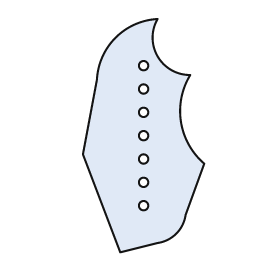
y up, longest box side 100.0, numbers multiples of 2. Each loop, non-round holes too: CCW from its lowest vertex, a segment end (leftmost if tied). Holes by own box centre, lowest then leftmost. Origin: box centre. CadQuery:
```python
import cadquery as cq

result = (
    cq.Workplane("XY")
    .moveTo(-10.0, -50.0)
    .lineTo(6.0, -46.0)
    .threePointArc((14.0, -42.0), (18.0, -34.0))
    .lineTo(26.0, -12.0)
    .threePointArc((16.0, 6.0), (20.0, 26.0))
    .threePointArc((6.0, 34.0), (6.0, 50.0))
    .threePointArc((-12.0, 42.0), (-20.0, 24.0))
    .lineTo(-26.0, -8.0)
    .close()
    .moveTo(0.0, -30.0)
    .circle(2.0)
    .moveTo(0.0, -20.0)
    .circle(2.0)
    .moveTo(0.0, -10.0)
    .circle(2.0)
    .moveTo(0.0, 0.0)
    .circle(2.0)
    .moveTo(0.0, 10.0)
    .circle(2.0)
    .moveTo(0.0, 20.0)
    .circle(2.0)
    .moveTo(0.0, 30.0)
    .circle(2.0)
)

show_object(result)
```